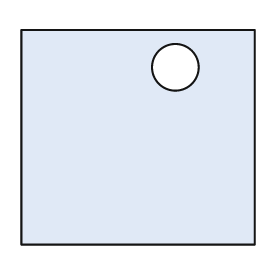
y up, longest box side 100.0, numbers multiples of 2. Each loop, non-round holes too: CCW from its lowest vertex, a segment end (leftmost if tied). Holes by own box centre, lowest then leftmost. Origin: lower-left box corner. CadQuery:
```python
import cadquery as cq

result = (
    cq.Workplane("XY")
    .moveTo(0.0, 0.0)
    .lineTo(100.0, 0.0)
    .lineTo(100.0, 92.0)
    .lineTo(0.0, 92.0)
    .close()
    .moveTo(66.0, 76.0)
    .circle(10.0)
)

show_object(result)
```